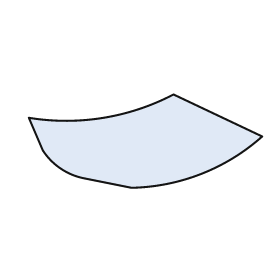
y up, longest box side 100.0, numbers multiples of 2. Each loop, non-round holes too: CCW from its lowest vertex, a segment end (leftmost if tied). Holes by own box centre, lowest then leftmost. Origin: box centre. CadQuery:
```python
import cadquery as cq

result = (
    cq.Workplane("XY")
    .moveTo(-6.0, -20.0)
    .threePointArc((24.0, -14.0), (50.0, 2.0))
    .lineTo(12.0, 20.0)
    .threePointArc((-18.0, 10.0), (-50.0, 10.0))
    .lineTo(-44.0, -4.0)
    .threePointArc((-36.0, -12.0), (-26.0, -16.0))
    .close()
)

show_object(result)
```